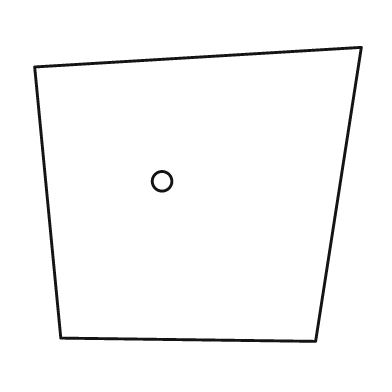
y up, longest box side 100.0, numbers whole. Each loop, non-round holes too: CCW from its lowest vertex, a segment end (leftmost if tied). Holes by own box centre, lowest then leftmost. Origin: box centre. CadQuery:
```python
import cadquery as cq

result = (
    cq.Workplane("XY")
    .moveTo(36.0, -45.0)
    .lineTo(50.0, 45.0)
    .lineTo(-50.0, 39.0)
    .lineTo(-42.0, -44.0)
    .close()
    .moveTo(-11.0, 4.0)
    .circle(3.0)
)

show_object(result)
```